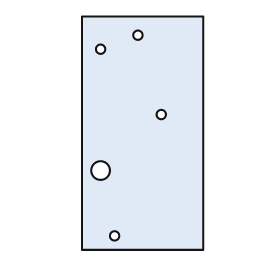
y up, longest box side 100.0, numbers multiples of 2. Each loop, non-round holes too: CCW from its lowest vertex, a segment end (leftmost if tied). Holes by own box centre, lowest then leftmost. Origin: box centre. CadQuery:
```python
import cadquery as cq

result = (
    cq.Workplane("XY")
    .moveTo(-26.0, -50.0)
    .lineTo(26.0, -50.0)
    .lineTo(26.0, 50.0)
    .lineTo(-26.0, 50.0)
    .close()
    .moveTo(-12.0, -44.0)
    .circle(2.0)
    .moveTo(-18.0, -16.0)
    .circle(4.0)
    .moveTo(8.0, 8.0)
    .circle(2.0)
    .moveTo(-18.0, 36.0)
    .circle(2.0)
    .moveTo(-2.0, 42.0)
    .circle(2.0)
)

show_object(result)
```